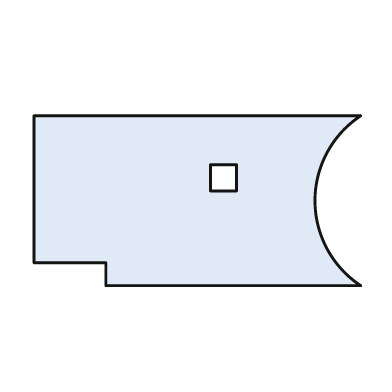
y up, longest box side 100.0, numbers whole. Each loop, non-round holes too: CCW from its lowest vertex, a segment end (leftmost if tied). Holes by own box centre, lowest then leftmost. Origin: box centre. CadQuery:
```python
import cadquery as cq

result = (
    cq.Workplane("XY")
    .moveTo(-28.0, -26.0)
    .lineTo(50.0, -26.0)
    .threePointArc((36.0, 0.0), (50.0, 26.0))
    .lineTo(-50.0, 26.0)
    .lineTo(-50.0, -19.0)
    .lineTo(-28.0, -19.0)
    .close()
    .moveTo(4.0, 3.0)
    .lineTo(12.0, 3.0)
    .lineTo(12.0, 11.0)
    .lineTo(4.0, 11.0)
    .close()
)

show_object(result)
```